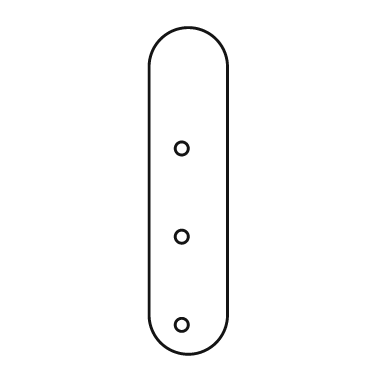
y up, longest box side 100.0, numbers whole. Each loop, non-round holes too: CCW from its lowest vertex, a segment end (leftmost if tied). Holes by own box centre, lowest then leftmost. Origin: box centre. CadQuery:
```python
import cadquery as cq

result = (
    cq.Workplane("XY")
    .moveTo(-12.0, -38.0)
    .threePointArc((0.0, -50.0), (12.0, -38.0))
    .lineTo(12.0, 38.0)
    .threePointArc((0.0, 50.0), (-12.0, 38.0))
    .close()
    .moveTo(-2.0, -41.0)
    .circle(2.0)
    .moveTo(-2.0, -14.0)
    .circle(2.0)
    .moveTo(-2.0, 13.0)
    .circle(2.0)
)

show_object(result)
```